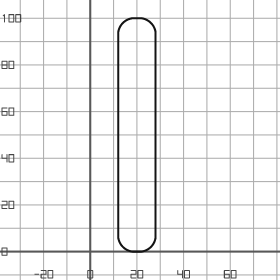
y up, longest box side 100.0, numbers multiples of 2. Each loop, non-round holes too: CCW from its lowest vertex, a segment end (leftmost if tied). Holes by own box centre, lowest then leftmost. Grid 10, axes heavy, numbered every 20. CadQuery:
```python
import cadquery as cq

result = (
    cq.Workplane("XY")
    .moveTo(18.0, 0.0)
    .lineTo(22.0, 0.0)
    .threePointArc((26.0, 2.0), (28.0, 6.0))
    .lineTo(28.0, 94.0)
    .threePointArc((26.0, 98.0), (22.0, 100.0))
    .lineTo(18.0, 100.0)
    .threePointArc((14.0, 98.0), (12.0, 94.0))
    .lineTo(12.0, 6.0)
    .threePointArc((14.0, 2.0), (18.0, 0.0))
    .close()
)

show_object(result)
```